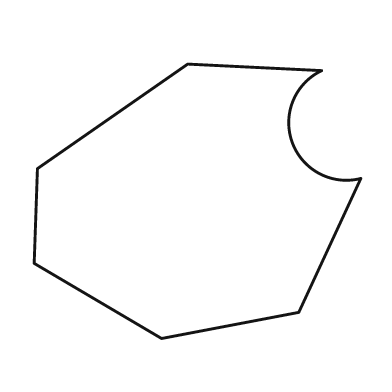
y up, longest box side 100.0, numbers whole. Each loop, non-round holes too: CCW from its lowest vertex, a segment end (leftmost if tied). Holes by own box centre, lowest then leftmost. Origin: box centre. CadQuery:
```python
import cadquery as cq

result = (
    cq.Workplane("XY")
    .moveTo(-11.0, -42.0)
    .lineTo(31.0, -34.0)
    .lineTo(50.0, 7.0)
    .threePointArc((29.0, 18.0), (38.0, 40.0))
    .lineTo(-3.0, 42.0)
    .lineTo(-49.0, 10.0)
    .lineTo(-50.0, -19.0)
    .close()
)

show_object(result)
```